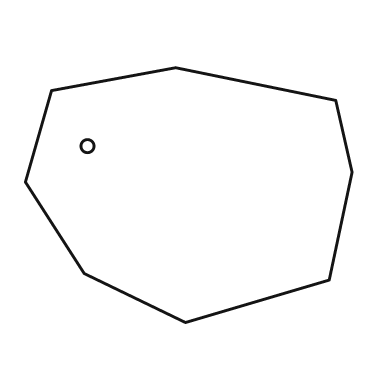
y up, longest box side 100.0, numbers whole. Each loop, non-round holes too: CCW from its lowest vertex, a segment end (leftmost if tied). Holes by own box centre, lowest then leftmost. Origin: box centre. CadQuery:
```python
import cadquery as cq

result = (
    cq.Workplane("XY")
    .moveTo(-1.0, -39.0)
    .lineTo(43.0, -26.0)
    .lineTo(50.0, 7.0)
    .lineTo(45.0, 29.0)
    .lineTo(-4.0, 39.0)
    .lineTo(-42.0, 32.0)
    .lineTo(-50.0, 4.0)
    .lineTo(-32.0, -24.0)
    .close()
    .moveTo(-31.0, 15.0)
    .circle(2.0)
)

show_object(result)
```